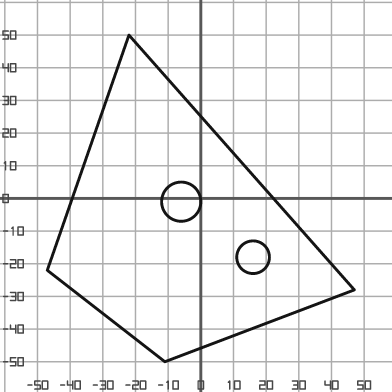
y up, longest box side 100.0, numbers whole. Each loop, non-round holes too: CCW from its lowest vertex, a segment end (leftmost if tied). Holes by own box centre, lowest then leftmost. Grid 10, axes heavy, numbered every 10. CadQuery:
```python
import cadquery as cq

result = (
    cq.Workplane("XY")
    .moveTo(-11.0, -50.0)
    .lineTo(47.0, -28.0)
    .lineTo(-22.0, 50.0)
    .lineTo(-47.0, -22.0)
    .close()
    .moveTo(16.0, -18.0)
    .circle(5.0)
    .moveTo(-6.0, -1.0)
    .circle(6.0)
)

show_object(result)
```